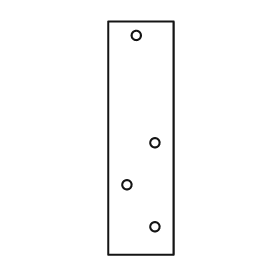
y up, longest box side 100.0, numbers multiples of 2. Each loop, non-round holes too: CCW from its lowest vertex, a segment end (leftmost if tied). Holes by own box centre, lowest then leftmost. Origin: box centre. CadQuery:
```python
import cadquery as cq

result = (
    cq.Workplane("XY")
    .moveTo(-14.0, -50.0)
    .lineTo(14.0, -50.0)
    .lineTo(14.0, 50.0)
    .lineTo(-14.0, 50.0)
    .close()
    .moveTo(6.0, -38.0)
    .circle(2.0)
    .moveTo(-6.0, -20.0)
    .circle(2.0)
    .moveTo(6.0, -2.0)
    .circle(2.0)
    .moveTo(-2.0, 44.0)
    .circle(2.0)
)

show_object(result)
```